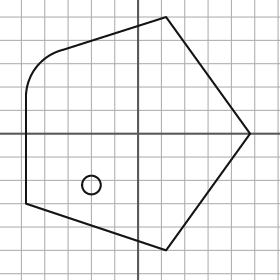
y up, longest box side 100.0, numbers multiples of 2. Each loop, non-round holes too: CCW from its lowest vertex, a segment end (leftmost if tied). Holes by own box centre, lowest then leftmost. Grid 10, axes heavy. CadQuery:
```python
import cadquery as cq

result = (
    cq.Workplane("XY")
    .moveTo(12.0, -50.0)
    .lineTo(48.0, 0.0)
    .lineTo(12.0, 50.0)
    .lineTo(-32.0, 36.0)
    .threePointArc((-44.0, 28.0), (-48.0, 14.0))
    .lineTo(-48.0, -30.0)
    .close()
    .moveTo(-20.0, -22.0)
    .circle(4.0)
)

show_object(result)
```